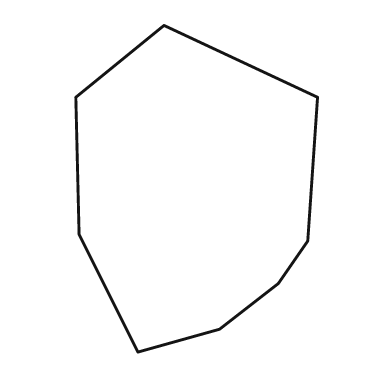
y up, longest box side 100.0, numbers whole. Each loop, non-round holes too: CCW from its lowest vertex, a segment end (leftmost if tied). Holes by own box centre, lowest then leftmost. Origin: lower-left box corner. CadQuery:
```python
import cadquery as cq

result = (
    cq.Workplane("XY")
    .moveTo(19.0, 0.0)
    .lineTo(44.0, 7.0)
    .lineTo(62.0, 21.0)
    .lineTo(71.0, 34.0)
    .lineTo(74.0, 78.0)
    .lineTo(27.0, 100.0)
    .lineTo(0.0, 78.0)
    .lineTo(1.0, 36.0)
    .close()
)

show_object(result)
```